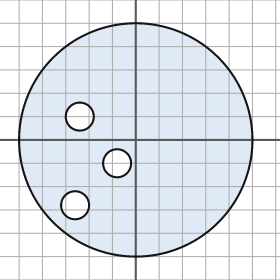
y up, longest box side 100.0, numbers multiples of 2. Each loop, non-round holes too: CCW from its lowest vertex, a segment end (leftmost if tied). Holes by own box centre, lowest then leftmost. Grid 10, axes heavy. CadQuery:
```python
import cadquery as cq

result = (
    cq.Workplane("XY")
    .moveTo(0.0, 0.0)
    .circle(50.0)
    .moveTo(-26.0, -28.0)
    .circle(6.0)
    .moveTo(-8.0, -10.0)
    .circle(6.0)
    .moveTo(-24.0, 10.0)
    .circle(6.0)
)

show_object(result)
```